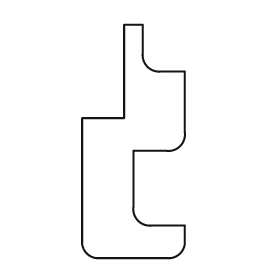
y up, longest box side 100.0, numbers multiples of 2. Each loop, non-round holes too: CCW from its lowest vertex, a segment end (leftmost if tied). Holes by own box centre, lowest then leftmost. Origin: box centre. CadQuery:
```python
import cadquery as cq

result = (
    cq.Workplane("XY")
    .moveTo(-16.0, -50.0)
    .lineTo(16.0, -50.0)
    .threePointArc((20.0, -48.0), (22.0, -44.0))
    .lineTo(22.0, -36.0)
    .lineTo(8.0, -36.0)
    .threePointArc((2.0, -34.0), (0.0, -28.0))
    .lineTo(0.0, -4.0)
    .lineTo(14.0, -4.0)
    .threePointArc((20.0, -2.0), (22.0, 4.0))
    .lineTo(22.0, 30.0)
    .lineTo(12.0, 30.0)
    .threePointArc((6.0, 32.0), (4.0, 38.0))
    .lineTo(4.0, 50.0)
    .lineTo(-4.0, 50.0)
    .lineTo(-4.0, 10.0)
    .lineTo(-22.0, 10.0)
    .lineTo(-22.0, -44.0)
    .threePointArc((-20.0, -48.0), (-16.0, -50.0))
    .close()
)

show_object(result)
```